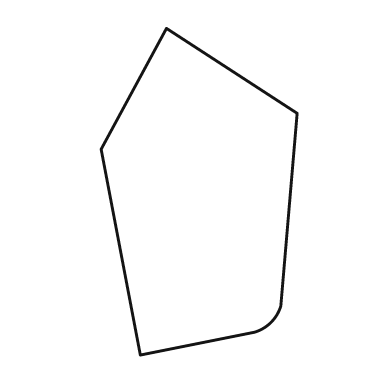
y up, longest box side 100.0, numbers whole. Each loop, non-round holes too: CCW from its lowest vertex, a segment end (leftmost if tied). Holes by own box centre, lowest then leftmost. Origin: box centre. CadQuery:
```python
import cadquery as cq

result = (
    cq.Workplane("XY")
    .moveTo(-18.0, -50.0)
    .lineTo(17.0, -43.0)
    .threePointArc((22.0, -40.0), (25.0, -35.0))
    .lineTo(30.0, 24.0)
    .lineTo(-10.0, 50.0)
    .lineTo(-30.0, 13.0)
    .close()
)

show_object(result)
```